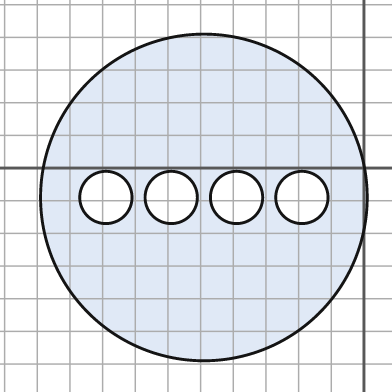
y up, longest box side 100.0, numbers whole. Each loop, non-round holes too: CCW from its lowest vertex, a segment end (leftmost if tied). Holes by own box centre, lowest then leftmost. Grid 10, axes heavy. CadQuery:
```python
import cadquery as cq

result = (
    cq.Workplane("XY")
    .moveTo(-49.0, -9.0)
    .circle(50.0)
    .moveTo(-79.0, -9.0)
    .circle(8.0)
    .moveTo(-59.0, -9.0)
    .circle(8.0)
    .moveTo(-39.0, -9.0)
    .circle(8.0)
    .moveTo(-19.0, -9.0)
    .circle(8.0)
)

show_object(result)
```